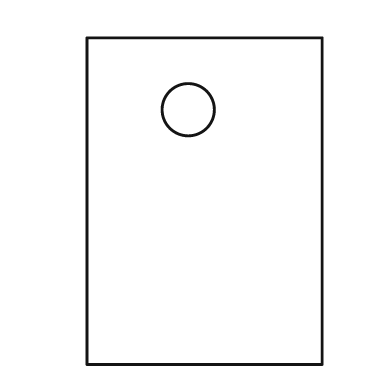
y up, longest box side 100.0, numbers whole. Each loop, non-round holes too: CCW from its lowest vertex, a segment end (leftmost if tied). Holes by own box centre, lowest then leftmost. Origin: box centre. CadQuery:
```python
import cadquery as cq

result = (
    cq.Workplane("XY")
    .moveTo(-36.0, -50.0)
    .lineTo(36.0, -50.0)
    .lineTo(36.0, 50.0)
    .lineTo(-36.0, 50.0)
    .close()
    .moveTo(-5.0, 28.0)
    .circle(8.0)
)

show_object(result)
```